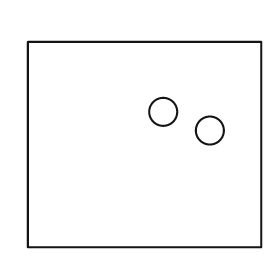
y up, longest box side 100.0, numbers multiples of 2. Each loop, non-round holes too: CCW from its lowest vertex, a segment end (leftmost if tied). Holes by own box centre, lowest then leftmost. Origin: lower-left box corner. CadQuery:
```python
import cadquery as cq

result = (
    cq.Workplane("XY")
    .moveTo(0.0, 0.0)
    .lineTo(100.0, 0.0)
    .lineTo(100.0, 88.0)
    .lineTo(0.0, 88.0)
    .close()
    .moveTo(78.0, 50.0)
    .circle(6.0)
    .moveTo(58.0, 58.0)
    .circle(6.0)
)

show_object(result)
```